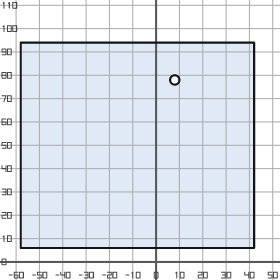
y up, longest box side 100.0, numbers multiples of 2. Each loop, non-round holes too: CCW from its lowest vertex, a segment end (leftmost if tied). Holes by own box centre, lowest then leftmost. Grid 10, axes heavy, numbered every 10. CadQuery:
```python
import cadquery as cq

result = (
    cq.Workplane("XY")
    .moveTo(-58.0, 6.0)
    .lineTo(42.0, 6.0)
    .lineTo(42.0, 94.0)
    .lineTo(-58.0, 94.0)
    .close()
    .moveTo(8.0, 78.0)
    .circle(2.0)
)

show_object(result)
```